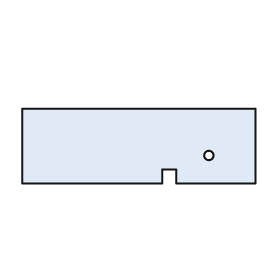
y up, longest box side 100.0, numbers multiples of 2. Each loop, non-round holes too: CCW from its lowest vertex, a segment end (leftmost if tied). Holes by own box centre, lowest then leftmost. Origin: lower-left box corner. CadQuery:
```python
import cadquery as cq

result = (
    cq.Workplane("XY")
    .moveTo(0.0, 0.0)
    .lineTo(60.0, 0.0)
    .lineTo(60.0, 6.0)
    .lineTo(66.0, 6.0)
    .lineTo(66.0, 0.0)
    .lineTo(100.0, 0.0)
    .lineTo(100.0, 32.0)
    .lineTo(0.0, 32.0)
    .close()
    .moveTo(80.0, 12.0)
    .circle(2.0)
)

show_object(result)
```